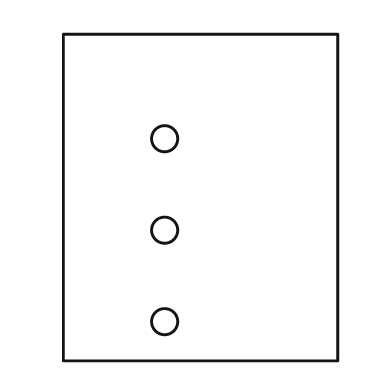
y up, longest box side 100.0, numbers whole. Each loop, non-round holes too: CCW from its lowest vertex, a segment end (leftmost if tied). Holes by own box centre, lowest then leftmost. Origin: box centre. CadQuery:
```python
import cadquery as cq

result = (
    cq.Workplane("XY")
    .moveTo(-42.0, -50.0)
    .lineTo(42.0, -50.0)
    .lineTo(42.0, 50.0)
    .lineTo(-42.0, 50.0)
    .close()
    .moveTo(-11.0, -38.0)
    .circle(4.0)
    .moveTo(-11.0, -10.0)
    .circle(4.0)
    .moveTo(-11.0, 18.0)
    .circle(4.0)
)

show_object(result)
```